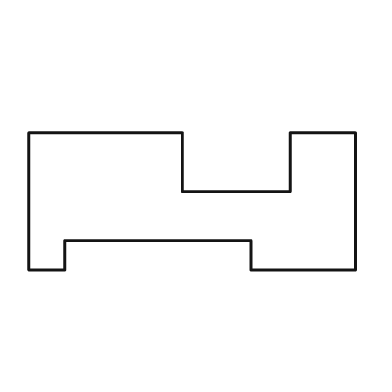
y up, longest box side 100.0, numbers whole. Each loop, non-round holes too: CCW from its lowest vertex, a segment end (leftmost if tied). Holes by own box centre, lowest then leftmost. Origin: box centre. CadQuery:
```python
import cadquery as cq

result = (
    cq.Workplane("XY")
    .moveTo(-50.0, -21.0)
    .lineTo(-39.0, -21.0)
    .lineTo(-39.0, -12.0)
    .lineTo(18.0, -12.0)
    .lineTo(18.0, -21.0)
    .lineTo(50.0, -21.0)
    .lineTo(50.0, 21.0)
    .lineTo(30.0, 21.0)
    .lineTo(30.0, 3.0)
    .lineTo(-3.0, 3.0)
    .lineTo(-3.0, 21.0)
    .lineTo(-50.0, 21.0)
    .close()
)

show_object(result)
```